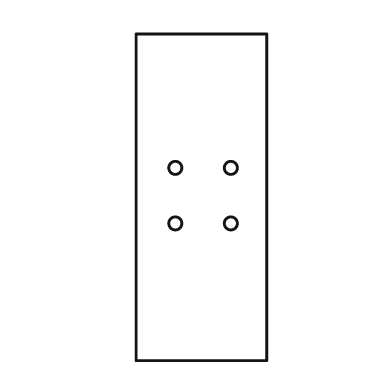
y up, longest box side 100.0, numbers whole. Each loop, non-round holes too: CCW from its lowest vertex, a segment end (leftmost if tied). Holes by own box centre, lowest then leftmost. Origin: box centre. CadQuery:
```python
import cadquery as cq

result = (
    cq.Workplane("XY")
    .moveTo(-20.0, -50.0)
    .lineTo(20.0, -50.0)
    .lineTo(20.0, 50.0)
    .lineTo(-20.0, 50.0)
    .close()
    .moveTo(-8.0, -8.0)
    .circle(2.0)
    .moveTo(9.0, -8.0)
    .circle(2.0)
    .moveTo(-8.0, 9.0)
    .circle(2.0)
    .moveTo(9.0, 9.0)
    .circle(2.0)
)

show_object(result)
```